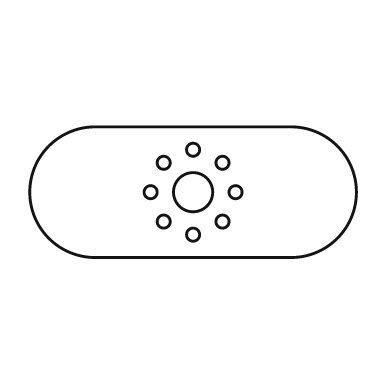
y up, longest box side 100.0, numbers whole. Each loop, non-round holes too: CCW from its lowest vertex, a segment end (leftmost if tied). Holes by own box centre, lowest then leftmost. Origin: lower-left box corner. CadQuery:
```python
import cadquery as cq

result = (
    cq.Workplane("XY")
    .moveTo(20.0, 0.0)
    .lineTo(80.0, 0.0)
    .threePointArc((100.0, 20.0), (80.0, 40.0))
    .lineTo(20.0, 40.0)
    .threePointArc((0.0, 20.0), (20.0, 0.0))
    .close()
    .moveTo(50.0, 7.0)
    .circle(2.0)
    .moveTo(41.0, 11.0)
    .circle(2.0)
    .moveTo(59.0, 11.0)
    .circle(2.0)
    .moveTo(37.0, 20.0)
    .circle(2.0)
    .moveTo(50.0, 20.0)
    .circle(6.0)
    .moveTo(63.0, 20.0)
    .circle(2.0)
    .moveTo(41.0, 29.0)
    .circle(2.0)
    .moveTo(59.0, 29.0)
    .circle(2.0)
    .moveTo(50.0, 33.0)
    .circle(2.0)
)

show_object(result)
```